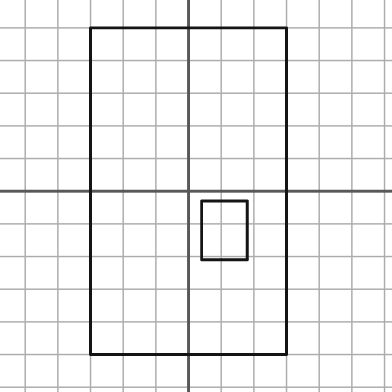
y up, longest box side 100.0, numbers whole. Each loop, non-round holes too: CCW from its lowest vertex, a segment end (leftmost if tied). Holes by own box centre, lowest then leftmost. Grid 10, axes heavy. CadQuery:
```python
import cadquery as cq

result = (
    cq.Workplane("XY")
    .moveTo(-30.0, -50.0)
    .lineTo(30.0, -50.0)
    .lineTo(30.0, 50.0)
    .lineTo(-30.0, 50.0)
    .close()
    .moveTo(4.0, -21.0)
    .lineTo(18.0, -21.0)
    .lineTo(18.0, -3.0)
    .lineTo(4.0, -3.0)
    .close()
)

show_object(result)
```